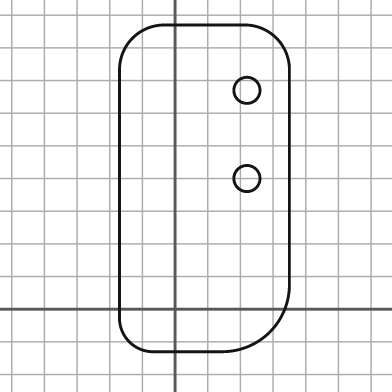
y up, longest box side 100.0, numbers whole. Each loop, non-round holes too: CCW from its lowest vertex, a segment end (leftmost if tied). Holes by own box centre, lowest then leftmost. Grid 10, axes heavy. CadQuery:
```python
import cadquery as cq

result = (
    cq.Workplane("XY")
    .moveTo(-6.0, -13.0)
    .lineTo(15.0, -13.0)
    .threePointArc((29.0, -7.0), (35.0, 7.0))
    .lineTo(35.0, 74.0)
    .threePointArc((31.0, 83.0), (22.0, 87.0))
    .lineTo(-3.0, 87.0)
    .threePointArc((-13.0, 83.0), (-17.0, 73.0))
    .lineTo(-17.0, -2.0)
    .threePointArc((-14.0, -10.0), (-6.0, -13.0))
    .close()
    .moveTo(22.0, 40.0)
    .circle(4.0)
    .moveTo(22.0, 67.0)
    .circle(4.0)
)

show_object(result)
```